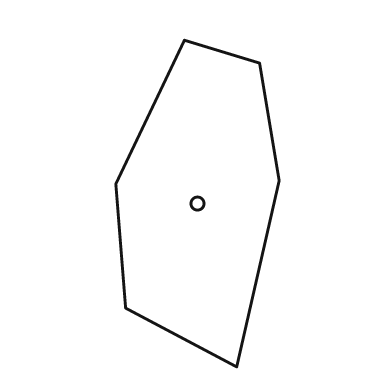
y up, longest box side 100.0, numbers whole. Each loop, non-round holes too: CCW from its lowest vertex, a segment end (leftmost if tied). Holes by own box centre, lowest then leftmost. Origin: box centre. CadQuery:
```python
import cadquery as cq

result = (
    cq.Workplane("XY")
    .moveTo(12.0, -50.0)
    .lineTo(25.0, 7.0)
    .lineTo(19.0, 43.0)
    .lineTo(-4.0, 50.0)
    .lineTo(-25.0, 6.0)
    .lineTo(-22.0, -32.0)
    .close()
    .moveTo(0.0, 0.0)
    .circle(2.0)
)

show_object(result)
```